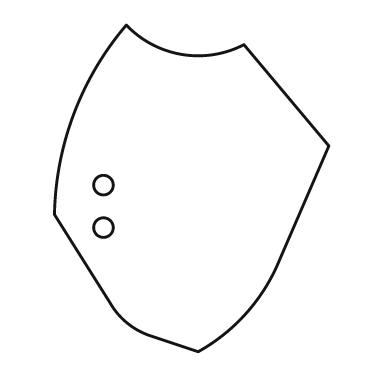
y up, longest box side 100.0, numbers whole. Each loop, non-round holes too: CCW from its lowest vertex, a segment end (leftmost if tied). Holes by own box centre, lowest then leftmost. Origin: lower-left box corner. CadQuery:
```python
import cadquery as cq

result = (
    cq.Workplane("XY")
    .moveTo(44.0, 0.0)
    .threePointArc((58.0, 11.0), (68.0, 26.0))
    .lineTo(84.0, 63.0)
    .lineTo(58.0, 94.0)
    .threePointArc((39.0, 91.0), (22.0, 100.0))
    .threePointArc((6.0, 73.0), (0.0, 42.0))
    .lineTo(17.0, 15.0)
    .threePointArc((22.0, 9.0), (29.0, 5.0))
    .close()
    .moveTo(15.0, 38.0)
    .circle(3.0)
    .moveTo(15.0, 51.0)
    .circle(3.0)
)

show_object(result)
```